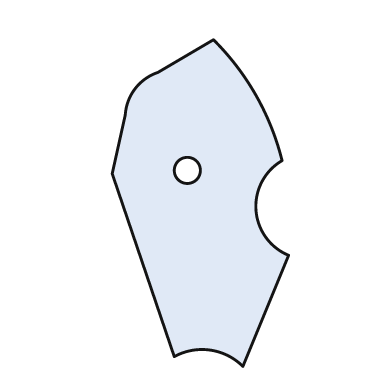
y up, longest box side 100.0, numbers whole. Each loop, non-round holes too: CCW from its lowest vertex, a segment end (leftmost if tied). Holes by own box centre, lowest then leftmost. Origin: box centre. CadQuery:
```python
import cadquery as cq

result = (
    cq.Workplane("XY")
    .moveTo(13.0, -50.0)
    .lineTo(27.0, -16.0)
    .threePointArc((17.0, -2.0), (25.0, 13.0))
    .threePointArc((17.0, 33.0), (4.0, 50.0))
    .lineTo(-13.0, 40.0)
    .threePointArc((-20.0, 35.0), (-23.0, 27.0))
    .lineTo(-27.0, 9.0)
    .lineTo(-8.0, -47.0)
    .threePointArc((3.0, -45.0), (13.0, -50.0))
    .close()
    .moveTo(-4.0, 10.0)
    .circle(4.0)
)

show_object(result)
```